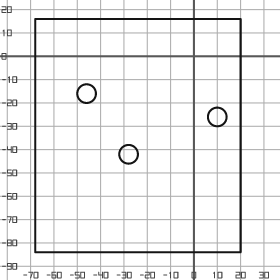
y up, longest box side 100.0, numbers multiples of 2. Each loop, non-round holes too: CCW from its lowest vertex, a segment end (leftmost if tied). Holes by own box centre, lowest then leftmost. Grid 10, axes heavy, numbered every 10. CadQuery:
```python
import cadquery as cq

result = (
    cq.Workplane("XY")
    .moveTo(-68.0, -84.0)
    .lineTo(20.0, -84.0)
    .lineTo(20.0, 16.0)
    .lineTo(-68.0, 16.0)
    .close()
    .moveTo(-28.0, -42.0)
    .circle(4.0)
    .moveTo(10.0, -26.0)
    .circle(4.0)
    .moveTo(-46.0, -16.0)
    .circle(4.0)
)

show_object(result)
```